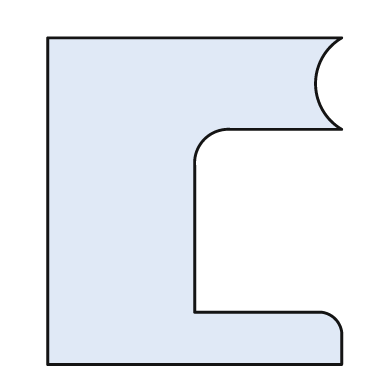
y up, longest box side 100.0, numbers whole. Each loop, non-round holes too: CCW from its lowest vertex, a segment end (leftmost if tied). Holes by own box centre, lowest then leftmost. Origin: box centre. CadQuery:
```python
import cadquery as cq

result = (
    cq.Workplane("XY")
    .moveTo(-45.0, -50.0)
    .lineTo(45.0, -50.0)
    .lineTo(45.0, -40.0)
    .threePointArc((43.0, -36.0), (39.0, -34.0))
    .lineTo(0.0, -34.0)
    .lineTo(0.0, 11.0)
    .threePointArc((3.0, 19.0), (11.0, 22.0))
    .lineTo(45.0, 22.0)
    .threePointArc((37.0, 36.0), (45.0, 50.0))
    .lineTo(-45.0, 50.0)
    .close()
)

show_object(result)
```